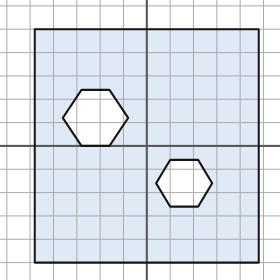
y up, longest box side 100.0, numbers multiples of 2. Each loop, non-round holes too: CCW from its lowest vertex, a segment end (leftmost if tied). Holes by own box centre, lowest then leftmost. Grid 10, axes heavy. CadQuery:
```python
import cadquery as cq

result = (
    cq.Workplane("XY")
    .moveTo(-48.0, -50.0)
    .lineTo(48.0, -50.0)
    .lineTo(48.0, 50.0)
    .lineTo(-48.0, 50.0)
    .close()
    .moveTo(10.0, -26.0)
    .lineTo(22.0, -26.0)
    .lineTo(28.0, -16.0)
    .lineTo(22.0, -6.0)
    .lineTo(10.0, -6.0)
    .lineTo(4.0, -16.0)
    .close()
    .moveTo(-28.0, 0.0)
    .lineTo(-16.0, 0.0)
    .lineTo(-8.0, 12.0)
    .lineTo(-16.0, 24.0)
    .lineTo(-28.0, 24.0)
    .lineTo(-36.0, 12.0)
    .close()
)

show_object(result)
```